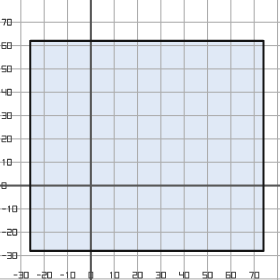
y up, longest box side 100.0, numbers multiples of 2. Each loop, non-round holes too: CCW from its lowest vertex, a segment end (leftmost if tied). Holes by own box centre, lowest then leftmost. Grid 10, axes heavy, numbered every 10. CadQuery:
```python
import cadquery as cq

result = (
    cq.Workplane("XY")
    .moveTo(-26.0, -28.0)
    .lineTo(74.0, -28.0)
    .lineTo(74.0, 62.0)
    .lineTo(-26.0, 62.0)
    .close()
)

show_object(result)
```